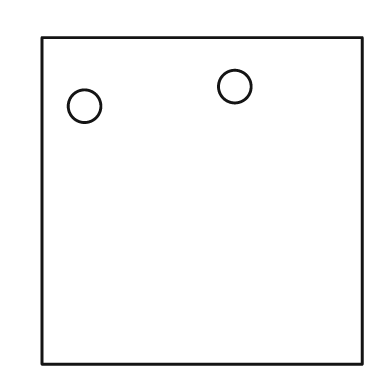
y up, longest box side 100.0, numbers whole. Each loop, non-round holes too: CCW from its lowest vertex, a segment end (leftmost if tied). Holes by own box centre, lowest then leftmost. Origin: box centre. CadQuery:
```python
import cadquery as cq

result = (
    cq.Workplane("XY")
    .moveTo(-49.0, -50.0)
    .lineTo(49.0, -50.0)
    .lineTo(49.0, 50.0)
    .lineTo(-49.0, 50.0)
    .close()
    .moveTo(-36.0, 29.0)
    .circle(5.0)
    .moveTo(10.0, 35.0)
    .circle(5.0)
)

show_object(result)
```